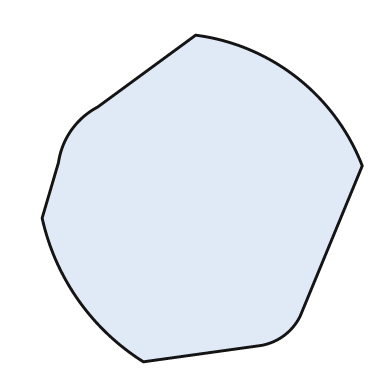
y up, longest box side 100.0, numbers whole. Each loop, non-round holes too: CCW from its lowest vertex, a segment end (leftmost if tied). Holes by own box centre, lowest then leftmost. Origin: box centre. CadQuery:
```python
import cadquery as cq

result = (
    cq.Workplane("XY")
    .moveTo(-18.0, -50.0)
    .lineTo(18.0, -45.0)
    .threePointArc((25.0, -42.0), (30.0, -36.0))
    .lineTo(49.0, 10.0)
    .threePointArc((29.0, 37.0), (-2.0, 50.0))
    .lineTo(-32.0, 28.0)
    .threePointArc((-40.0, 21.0), (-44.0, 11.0))
    .lineTo(-49.0, -6.0)
    .threePointArc((-38.0, -31.0), (-18.0, -50.0))
    .close()
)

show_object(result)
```